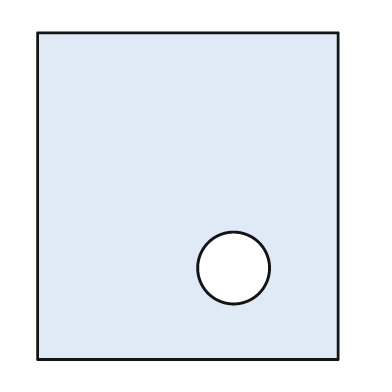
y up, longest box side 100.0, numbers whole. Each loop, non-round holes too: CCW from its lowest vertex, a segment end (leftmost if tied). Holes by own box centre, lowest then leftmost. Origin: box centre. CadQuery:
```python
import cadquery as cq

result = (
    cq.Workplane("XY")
    .moveTo(-46.0, -50.0)
    .lineTo(46.0, -50.0)
    .lineTo(46.0, 50.0)
    .lineTo(-46.0, 50.0)
    .close()
    .moveTo(14.0, -22.0)
    .circle(11.0)
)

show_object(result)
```